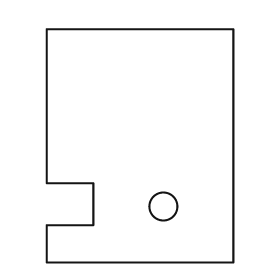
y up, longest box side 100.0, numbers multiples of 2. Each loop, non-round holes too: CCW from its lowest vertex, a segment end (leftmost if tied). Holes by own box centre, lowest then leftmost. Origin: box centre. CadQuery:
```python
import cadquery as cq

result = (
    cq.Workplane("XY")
    .moveTo(-40.0, -50.0)
    .lineTo(40.0, -50.0)
    .lineTo(40.0, 50.0)
    .lineTo(-40.0, 50.0)
    .lineTo(-40.0, -16.0)
    .lineTo(-20.0, -16.0)
    .lineTo(-20.0, -34.0)
    .lineTo(-40.0, -34.0)
    .close()
    .moveTo(10.0, -26.0)
    .circle(6.0)
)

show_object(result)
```